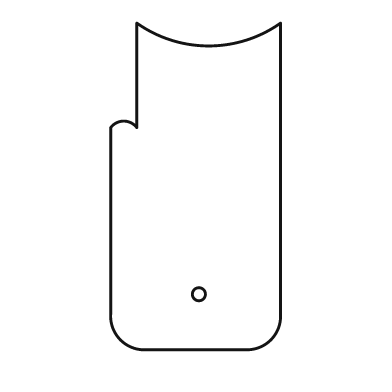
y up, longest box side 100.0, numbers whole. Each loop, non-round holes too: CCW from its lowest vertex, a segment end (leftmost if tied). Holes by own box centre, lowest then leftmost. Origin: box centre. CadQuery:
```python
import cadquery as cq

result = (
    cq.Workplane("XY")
    .moveTo(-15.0, -50.0)
    .lineTo(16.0, -50.0)
    .threePointArc((23.0, -47.0), (26.0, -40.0))
    .lineTo(26.0, 50.0)
    .threePointArc((4.0, 43.0), (-18.0, 50.0))
    .lineTo(-18.0, 18.0)
    .threePointArc((-22.0, 20.0), (-26.0, 18.0))
    .lineTo(-26.0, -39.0)
    .threePointArc((-23.0, -47.0), (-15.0, -50.0))
    .close()
    .moveTo(1.0, -33.0)
    .circle(2.0)
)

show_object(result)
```